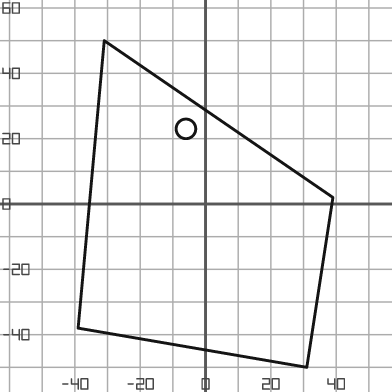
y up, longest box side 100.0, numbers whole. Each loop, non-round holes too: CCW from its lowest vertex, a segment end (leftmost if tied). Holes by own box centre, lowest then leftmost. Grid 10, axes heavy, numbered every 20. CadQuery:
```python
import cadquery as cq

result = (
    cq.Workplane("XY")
    .moveTo(31.0, -50.0)
    .lineTo(39.0, 2.0)
    .lineTo(-31.0, 50.0)
    .lineTo(-39.0, -38.0)
    .close()
    .moveTo(-6.0, 23.0)
    .circle(3.0)
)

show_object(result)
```